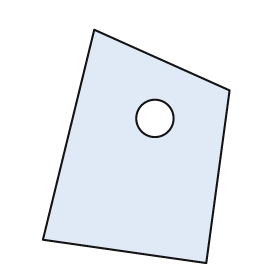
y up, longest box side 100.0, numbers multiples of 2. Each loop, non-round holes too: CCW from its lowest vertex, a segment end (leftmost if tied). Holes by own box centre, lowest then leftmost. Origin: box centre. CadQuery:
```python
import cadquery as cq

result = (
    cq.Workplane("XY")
    .moveTo(30.0, -50.0)
    .lineTo(40.0, 24.0)
    .lineTo(-18.0, 50.0)
    .lineTo(-40.0, -40.0)
    .close()
    .moveTo(8.0, 12.0)
    .circle(8.0)
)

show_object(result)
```